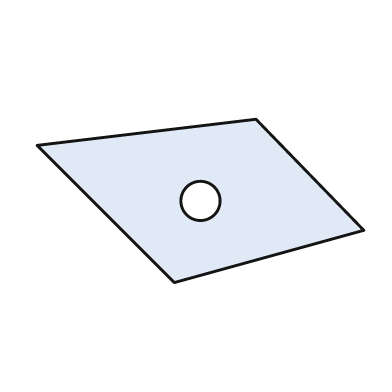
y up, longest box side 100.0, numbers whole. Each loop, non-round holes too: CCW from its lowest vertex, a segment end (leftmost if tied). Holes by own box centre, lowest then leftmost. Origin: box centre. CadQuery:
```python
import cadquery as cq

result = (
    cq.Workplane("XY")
    .moveTo(-8.0, -25.0)
    .lineTo(50.0, -9.0)
    .lineTo(17.0, 25.0)
    .lineTo(-50.0, 17.0)
    .close()
    .moveTo(0.0, 0.0)
    .circle(6.0)
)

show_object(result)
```